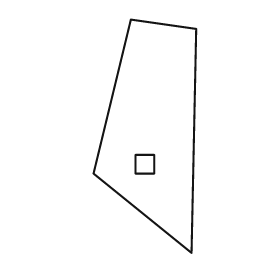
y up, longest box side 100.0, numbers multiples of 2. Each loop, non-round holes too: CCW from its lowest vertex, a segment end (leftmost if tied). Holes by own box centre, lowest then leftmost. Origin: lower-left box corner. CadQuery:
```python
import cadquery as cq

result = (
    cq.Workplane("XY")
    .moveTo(42.0, 0.0)
    .lineTo(44.0, 96.0)
    .lineTo(16.0, 100.0)
    .lineTo(0.0, 34.0)
    .close()
    .moveTo(18.0, 34.0)
    .lineTo(26.0, 34.0)
    .lineTo(26.0, 42.0)
    .lineTo(18.0, 42.0)
    .close()
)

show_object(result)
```